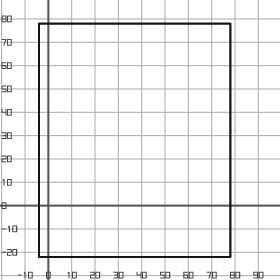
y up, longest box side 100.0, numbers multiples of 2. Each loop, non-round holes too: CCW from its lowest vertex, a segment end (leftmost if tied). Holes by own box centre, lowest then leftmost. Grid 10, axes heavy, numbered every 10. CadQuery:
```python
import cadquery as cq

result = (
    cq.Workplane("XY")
    .moveTo(-4.0, -22.0)
    .lineTo(78.0, -22.0)
    .lineTo(78.0, 78.0)
    .lineTo(-4.0, 78.0)
    .close()
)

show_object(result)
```